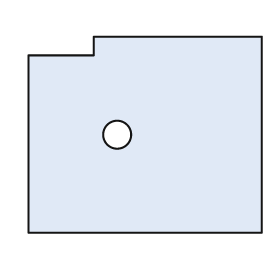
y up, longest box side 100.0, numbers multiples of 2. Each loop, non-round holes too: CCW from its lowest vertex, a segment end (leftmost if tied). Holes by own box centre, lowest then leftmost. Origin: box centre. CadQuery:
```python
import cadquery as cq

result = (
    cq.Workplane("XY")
    .moveTo(-50.0, -42.0)
    .lineTo(50.0, -42.0)
    .lineTo(50.0, 42.0)
    .lineTo(-22.0, 42.0)
    .lineTo(-22.0, 34.0)
    .lineTo(-50.0, 34.0)
    .close()
    .moveTo(-12.0, 0.0)
    .circle(6.0)
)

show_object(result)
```